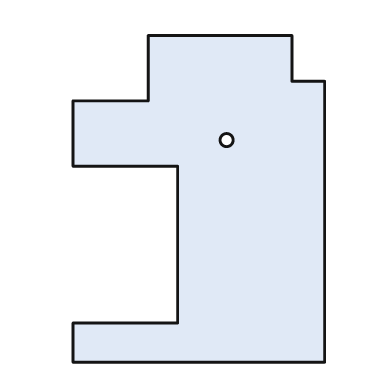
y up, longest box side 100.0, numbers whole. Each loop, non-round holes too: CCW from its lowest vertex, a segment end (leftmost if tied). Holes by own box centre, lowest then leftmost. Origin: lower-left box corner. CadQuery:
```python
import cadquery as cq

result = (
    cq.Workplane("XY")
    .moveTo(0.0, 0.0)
    .lineTo(77.0, 0.0)
    .lineTo(77.0, 86.0)
    .lineTo(67.0, 86.0)
    .lineTo(67.0, 100.0)
    .lineTo(23.0, 100.0)
    .lineTo(23.0, 80.0)
    .lineTo(0.0, 80.0)
    .lineTo(0.0, 60.0)
    .lineTo(32.0, 60.0)
    .lineTo(32.0, 12.0)
    .lineTo(0.0, 12.0)
    .close()
    .moveTo(47.0, 68.0)
    .circle(2.0)
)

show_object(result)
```